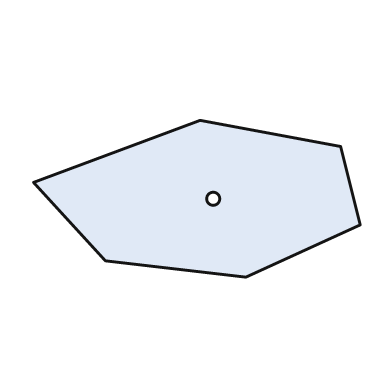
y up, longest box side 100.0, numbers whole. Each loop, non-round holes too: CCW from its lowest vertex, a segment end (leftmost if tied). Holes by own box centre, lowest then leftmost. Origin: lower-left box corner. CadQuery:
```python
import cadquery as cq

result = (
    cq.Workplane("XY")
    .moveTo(65.0, 0.0)
    .lineTo(100.0, 16.0)
    .lineTo(94.0, 40.0)
    .lineTo(51.0, 48.0)
    .lineTo(0.0, 29.0)
    .lineTo(22.0, 5.0)
    .close()
    .moveTo(55.0, 24.0)
    .circle(2.0)
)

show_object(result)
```